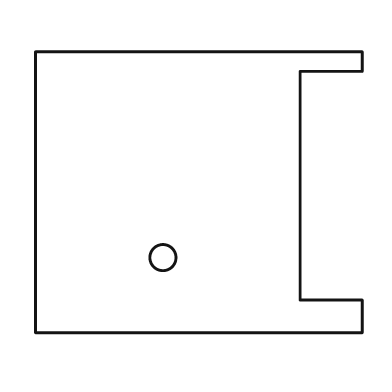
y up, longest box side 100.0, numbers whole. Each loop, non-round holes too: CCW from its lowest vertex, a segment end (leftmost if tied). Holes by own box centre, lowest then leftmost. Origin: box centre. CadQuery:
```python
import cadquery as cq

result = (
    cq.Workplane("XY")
    .moveTo(-50.0, -43.0)
    .lineTo(50.0, -43.0)
    .lineTo(50.0, -33.0)
    .lineTo(31.0, -33.0)
    .lineTo(31.0, 37.0)
    .lineTo(50.0, 37.0)
    .lineTo(50.0, 43.0)
    .lineTo(-50.0, 43.0)
    .close()
    .moveTo(-11.0, -20.0)
    .circle(4.0)
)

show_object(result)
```